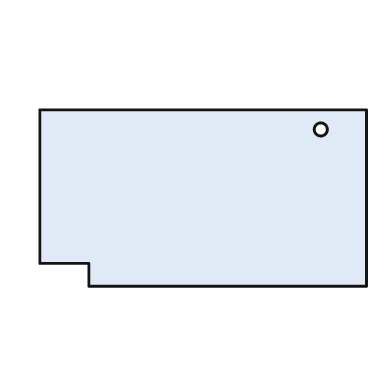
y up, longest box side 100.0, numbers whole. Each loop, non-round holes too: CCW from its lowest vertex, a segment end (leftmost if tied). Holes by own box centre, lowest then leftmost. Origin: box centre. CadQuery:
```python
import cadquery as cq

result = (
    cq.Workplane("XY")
    .moveTo(-35.0, -27.0)
    .lineTo(50.0, -27.0)
    .lineTo(50.0, 27.0)
    .lineTo(-50.0, 27.0)
    .lineTo(-50.0, -20.0)
    .lineTo(-35.0, -20.0)
    .close()
    .moveTo(36.0, 21.0)
    .circle(2.0)
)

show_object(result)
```